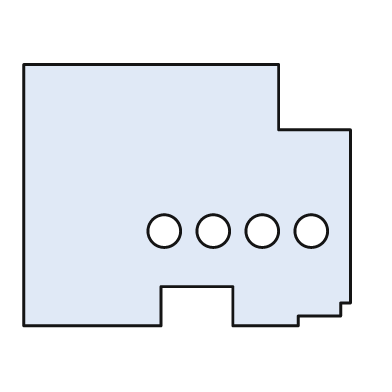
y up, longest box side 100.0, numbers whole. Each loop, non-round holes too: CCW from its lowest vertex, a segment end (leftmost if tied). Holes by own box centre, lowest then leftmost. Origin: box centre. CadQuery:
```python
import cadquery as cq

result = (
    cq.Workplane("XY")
    .moveTo(-50.0, -40.0)
    .lineTo(-8.0, -40.0)
    .lineTo(-8.0, -28.0)
    .lineTo(14.0, -28.0)
    .lineTo(14.0, -40.0)
    .lineTo(34.0, -40.0)
    .lineTo(34.0, -37.0)
    .lineTo(47.0, -37.0)
    .lineTo(47.0, -33.0)
    .lineTo(50.0, -33.0)
    .lineTo(50.0, 20.0)
    .lineTo(28.0, 20.0)
    .lineTo(28.0, 40.0)
    .lineTo(-50.0, 40.0)
    .close()
    .moveTo(-7.0, -11.0)
    .circle(5.0)
    .moveTo(8.0, -11.0)
    .circle(5.0)
    .moveTo(23.0, -11.0)
    .circle(5.0)
    .moveTo(38.0, -11.0)
    .circle(5.0)
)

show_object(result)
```